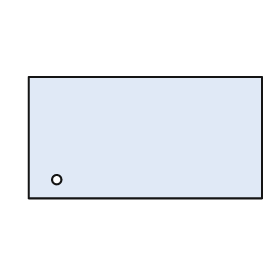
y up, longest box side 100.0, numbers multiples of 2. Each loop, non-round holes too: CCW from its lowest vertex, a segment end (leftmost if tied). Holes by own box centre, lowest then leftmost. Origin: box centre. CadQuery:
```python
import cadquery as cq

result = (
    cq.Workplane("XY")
    .moveTo(-50.0, -26.0)
    .lineTo(50.0, -26.0)
    .lineTo(50.0, 26.0)
    .lineTo(-50.0, 26.0)
    .close()
    .moveTo(-38.0, -18.0)
    .circle(2.0)
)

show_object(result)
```